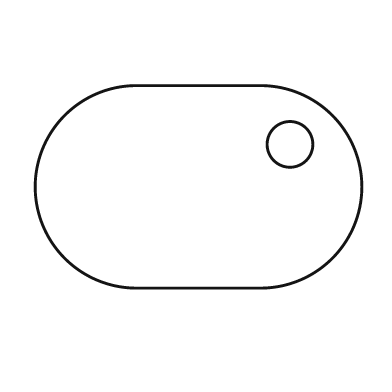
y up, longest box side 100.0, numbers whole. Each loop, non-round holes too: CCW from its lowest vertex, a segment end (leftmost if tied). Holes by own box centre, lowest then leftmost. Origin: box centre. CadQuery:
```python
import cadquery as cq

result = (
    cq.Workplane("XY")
    .moveTo(-19.0, -31.0)
    .lineTo(19.0, -31.0)
    .threePointArc((50.0, 0.0), (19.0, 31.0))
    .lineTo(-19.0, 31.0)
    .threePointArc((-50.0, 0.0), (-19.0, -31.0))
    .close()
    .moveTo(28.0, 13.0)
    .circle(7.0)
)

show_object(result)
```